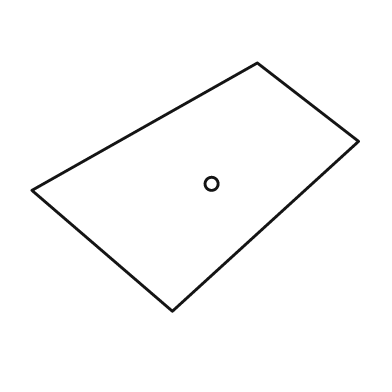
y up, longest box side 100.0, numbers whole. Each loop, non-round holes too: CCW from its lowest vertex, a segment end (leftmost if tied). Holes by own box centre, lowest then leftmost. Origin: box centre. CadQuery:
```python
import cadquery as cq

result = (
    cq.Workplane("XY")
    .moveTo(-7.0, -38.0)
    .lineTo(50.0, 14.0)
    .lineTo(19.0, 38.0)
    .lineTo(-50.0, -1.0)
    .close()
    .moveTo(5.0, 1.0)
    .circle(2.0)
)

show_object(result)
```